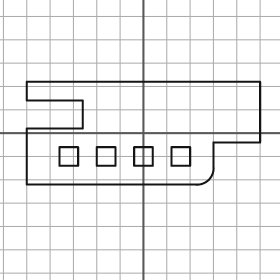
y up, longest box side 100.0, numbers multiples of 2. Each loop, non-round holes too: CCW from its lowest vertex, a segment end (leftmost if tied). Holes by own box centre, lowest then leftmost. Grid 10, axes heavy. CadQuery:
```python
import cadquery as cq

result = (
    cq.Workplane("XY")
    .moveTo(-50.0, -22.0)
    .lineTo(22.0, -22.0)
    .threePointArc((28.0, -20.0), (30.0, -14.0))
    .lineTo(30.0, -4.0)
    .lineTo(50.0, -4.0)
    .lineTo(50.0, 22.0)
    .lineTo(-50.0, 22.0)
    .lineTo(-50.0, 14.0)
    .lineTo(-26.0, 14.0)
    .lineTo(-26.0, 2.0)
    .lineTo(-50.0, 2.0)
    .close()
    .moveTo(-36.0, -14.0)
    .lineTo(-28.0, -14.0)
    .lineTo(-28.0, -6.0)
    .lineTo(-36.0, -6.0)
    .close()
    .moveTo(-20.0, -14.0)
    .lineTo(-12.0, -14.0)
    .lineTo(-12.0, -6.0)
    .lineTo(-20.0, -6.0)
    .close()
    .moveTo(-4.0, -14.0)
    .lineTo(4.0, -14.0)
    .lineTo(4.0, -6.0)
    .lineTo(-4.0, -6.0)
    .close()
    .moveTo(12.0, -14.0)
    .lineTo(20.0, -14.0)
    .lineTo(20.0, -6.0)
    .lineTo(12.0, -6.0)
    .close()
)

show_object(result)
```